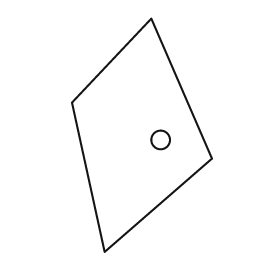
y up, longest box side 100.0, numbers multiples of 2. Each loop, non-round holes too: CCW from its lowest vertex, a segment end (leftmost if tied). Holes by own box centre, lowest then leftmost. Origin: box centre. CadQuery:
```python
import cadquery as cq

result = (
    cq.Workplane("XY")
    .moveTo(-16.0, -50.0)
    .lineTo(30.0, -10.0)
    .lineTo(4.0, 50.0)
    .lineTo(-30.0, 14.0)
    .close()
    .moveTo(8.0, -2.0)
    .circle(4.0)
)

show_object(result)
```